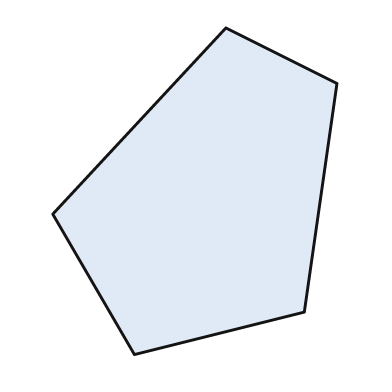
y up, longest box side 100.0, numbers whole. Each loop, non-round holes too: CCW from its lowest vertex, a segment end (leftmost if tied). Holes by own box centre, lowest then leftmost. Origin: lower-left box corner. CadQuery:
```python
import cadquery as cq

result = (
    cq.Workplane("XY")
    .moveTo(25.0, 0.0)
    .lineTo(77.0, 13.0)
    .lineTo(87.0, 83.0)
    .lineTo(53.0, 100.0)
    .lineTo(0.0, 43.0)
    .close()
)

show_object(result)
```